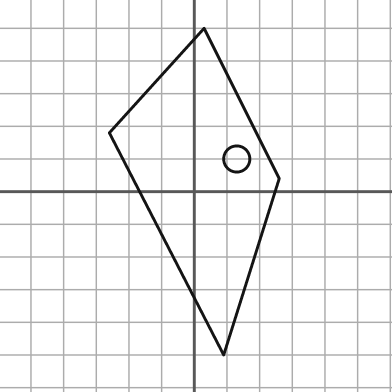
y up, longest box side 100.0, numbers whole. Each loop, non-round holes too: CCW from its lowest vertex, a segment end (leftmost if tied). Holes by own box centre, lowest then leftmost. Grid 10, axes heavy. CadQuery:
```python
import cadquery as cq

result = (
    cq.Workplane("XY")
    .moveTo(9.0, -50.0)
    .lineTo(26.0, 4.0)
    .lineTo(3.0, 50.0)
    .lineTo(-26.0, 18.0)
    .close()
    .moveTo(13.0, 10.0)
    .circle(4.0)
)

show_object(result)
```